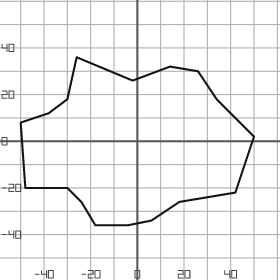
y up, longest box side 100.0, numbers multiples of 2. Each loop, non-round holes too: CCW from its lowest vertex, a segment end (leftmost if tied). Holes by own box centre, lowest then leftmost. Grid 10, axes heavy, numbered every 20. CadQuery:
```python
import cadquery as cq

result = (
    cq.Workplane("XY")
    .moveTo(-18.0, -36.0)
    .lineTo(-4.0, -36.0)
    .lineTo(6.0, -34.0)
    .lineTo(18.0, -26.0)
    .lineTo(42.0, -22.0)
    .lineTo(50.0, 2.0)
    .lineTo(34.0, 18.0)
    .lineTo(26.0, 30.0)
    .lineTo(14.0, 32.0)
    .lineTo(-2.0, 26.0)
    .lineTo(-26.0, 36.0)
    .lineTo(-30.0, 18.0)
    .lineTo(-38.0, 12.0)
    .lineTo(-50.0, 8.0)
    .lineTo(-48.0, -20.0)
    .lineTo(-30.0, -20.0)
    .lineTo(-24.0, -26.0)
    .close()
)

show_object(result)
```